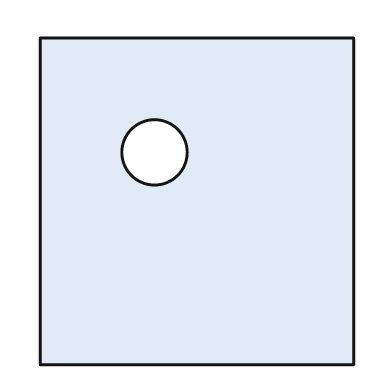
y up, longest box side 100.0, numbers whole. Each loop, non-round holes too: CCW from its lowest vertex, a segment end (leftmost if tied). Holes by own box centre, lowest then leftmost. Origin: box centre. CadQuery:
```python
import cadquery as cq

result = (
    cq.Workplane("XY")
    .moveTo(-48.0, -50.0)
    .lineTo(48.0, -50.0)
    .lineTo(48.0, 50.0)
    .lineTo(-48.0, 50.0)
    .close()
    .moveTo(-13.0, 15.0)
    .circle(10.0)
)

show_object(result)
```